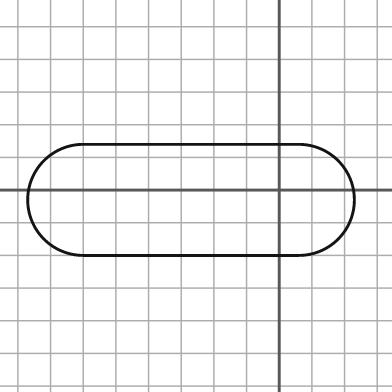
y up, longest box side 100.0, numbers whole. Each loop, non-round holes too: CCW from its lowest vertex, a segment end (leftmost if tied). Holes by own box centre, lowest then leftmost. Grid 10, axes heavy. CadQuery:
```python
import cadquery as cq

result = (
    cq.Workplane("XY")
    .moveTo(-60.0, -20.0)
    .lineTo(6.0, -20.0)
    .threePointArc((23.0, -3.0), (6.0, 14.0))
    .lineTo(-60.0, 14.0)
    .threePointArc((-77.0, -3.0), (-60.0, -20.0))
    .close()
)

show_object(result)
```